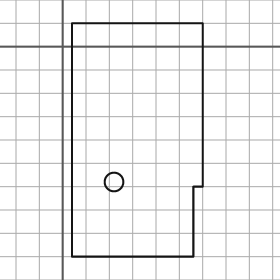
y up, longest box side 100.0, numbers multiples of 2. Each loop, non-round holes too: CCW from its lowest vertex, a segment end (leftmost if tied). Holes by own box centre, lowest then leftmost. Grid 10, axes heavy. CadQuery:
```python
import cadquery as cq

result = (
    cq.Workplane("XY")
    .moveTo(4.0, -90.0)
    .lineTo(56.0, -90.0)
    .lineTo(56.0, -60.0)
    .lineTo(60.0, -60.0)
    .lineTo(60.0, 10.0)
    .lineTo(4.0, 10.0)
    .close()
    .moveTo(22.0, -58.0)
    .circle(4.0)
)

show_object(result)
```